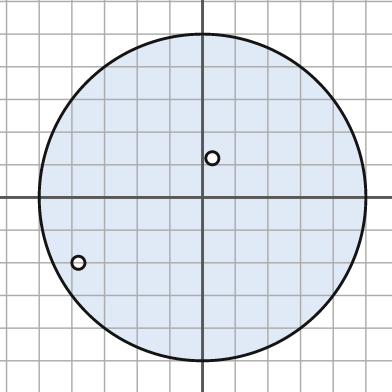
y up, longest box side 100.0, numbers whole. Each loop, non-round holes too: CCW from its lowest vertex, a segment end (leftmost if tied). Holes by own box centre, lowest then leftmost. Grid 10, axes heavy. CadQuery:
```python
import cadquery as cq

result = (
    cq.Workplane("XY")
    .moveTo(0.0, 0.0)
    .circle(50.0)
    .moveTo(-38.0, -20.0)
    .circle(2.0)
    .moveTo(3.0, 12.0)
    .circle(2.0)
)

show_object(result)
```